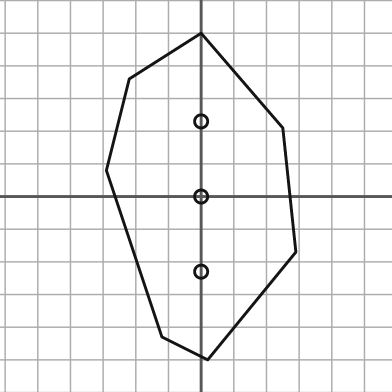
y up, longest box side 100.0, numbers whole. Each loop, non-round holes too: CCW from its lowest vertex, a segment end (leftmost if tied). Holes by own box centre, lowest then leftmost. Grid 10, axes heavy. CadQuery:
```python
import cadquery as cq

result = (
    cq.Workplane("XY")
    .moveTo(2.0, -50.0)
    .lineTo(29.0, -17.0)
    .lineTo(25.0, 21.0)
    .lineTo(0.0, 50.0)
    .lineTo(-22.0, 36.0)
    .lineTo(-29.0, 8.0)
    .lineTo(-12.0, -43.0)
    .close()
    .moveTo(0.0, -23.0)
    .circle(2.0)
    .moveTo(0.0, 0.0)
    .circle(2.0)
    .moveTo(0.0, 23.0)
    .circle(2.0)
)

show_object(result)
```